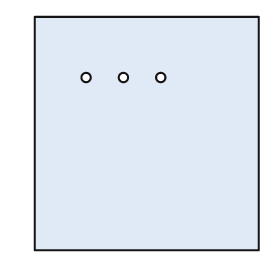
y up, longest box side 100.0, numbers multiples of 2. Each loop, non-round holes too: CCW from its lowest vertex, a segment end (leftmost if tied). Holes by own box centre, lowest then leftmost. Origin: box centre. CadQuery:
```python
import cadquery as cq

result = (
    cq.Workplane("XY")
    .moveTo(-48.0, -50.0)
    .lineTo(48.0, -50.0)
    .lineTo(48.0, 50.0)
    .lineTo(-48.0, 50.0)
    .close()
    .moveTo(-26.0, 24.0)
    .circle(2.0)
    .moveTo(-10.0, 24.0)
    .circle(2.0)
    .moveTo(6.0, 24.0)
    .circle(2.0)
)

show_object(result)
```